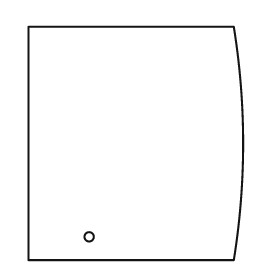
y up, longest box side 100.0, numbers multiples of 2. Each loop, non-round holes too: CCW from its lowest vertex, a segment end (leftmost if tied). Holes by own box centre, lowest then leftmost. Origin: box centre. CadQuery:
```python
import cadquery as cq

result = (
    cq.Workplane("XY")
    .moveTo(-46.0, -50.0)
    .lineTo(42.0, -50.0)
    .threePointArc((46.0, 0.0), (42.0, 50.0))
    .lineTo(-46.0, 50.0)
    .close()
    .moveTo(-20.0, -40.0)
    .circle(2.0)
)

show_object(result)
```